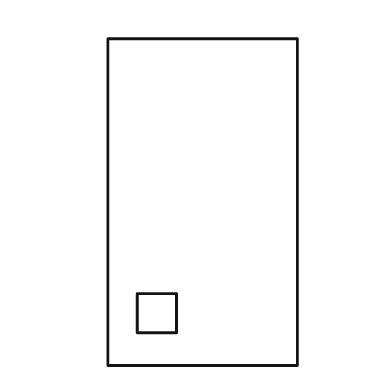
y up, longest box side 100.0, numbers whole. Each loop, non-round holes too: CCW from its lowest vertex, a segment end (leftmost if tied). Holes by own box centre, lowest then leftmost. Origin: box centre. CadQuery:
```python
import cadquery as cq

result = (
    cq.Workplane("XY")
    .moveTo(-29.0, -50.0)
    .lineTo(29.0, -50.0)
    .lineTo(29.0, 50.0)
    .lineTo(-29.0, 50.0)
    .close()
    .moveTo(-20.0, -40.0)
    .lineTo(-8.0, -40.0)
    .lineTo(-8.0, -28.0)
    .lineTo(-20.0, -28.0)
    .close()
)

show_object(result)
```